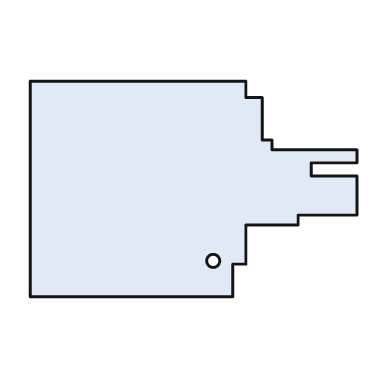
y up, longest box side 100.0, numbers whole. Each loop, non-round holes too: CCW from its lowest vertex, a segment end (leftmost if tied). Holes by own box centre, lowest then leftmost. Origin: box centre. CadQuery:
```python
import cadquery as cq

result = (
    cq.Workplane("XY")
    .moveTo(-50.0, -33.0)
    .lineTo(12.0, -33.0)
    .lineTo(12.0, -23.0)
    .lineTo(16.0, -23.0)
    .lineTo(16.0, -11.0)
    .lineTo(32.0, -11.0)
    .lineTo(32.0, -8.0)
    .lineTo(50.0, -8.0)
    .lineTo(50.0, 4.0)
    .lineTo(36.0, 4.0)
    .lineTo(36.0, 8.0)
    .lineTo(50.0, 8.0)
    .lineTo(50.0, 12.0)
    .lineTo(24.0, 12.0)
    .lineTo(24.0, 15.0)
    .lineTo(21.0, 15.0)
    .lineTo(21.0, 28.0)
    .lineTo(16.0, 28.0)
    .lineTo(16.0, 33.0)
    .lineTo(-50.0, 33.0)
    .close()
    .moveTo(6.0, -22.0)
    .circle(2.0)
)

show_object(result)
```